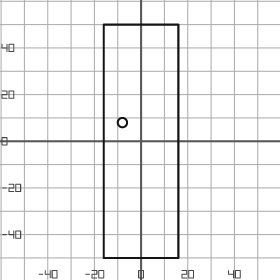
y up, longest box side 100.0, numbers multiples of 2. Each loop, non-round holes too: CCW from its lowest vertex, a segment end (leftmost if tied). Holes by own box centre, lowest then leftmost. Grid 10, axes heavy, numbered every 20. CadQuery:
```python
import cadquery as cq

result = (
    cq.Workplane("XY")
    .moveTo(-16.0, -50.0)
    .lineTo(16.0, -50.0)
    .lineTo(16.0, 50.0)
    .lineTo(-16.0, 50.0)
    .close()
    .moveTo(-8.0, 8.0)
    .circle(2.0)
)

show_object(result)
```